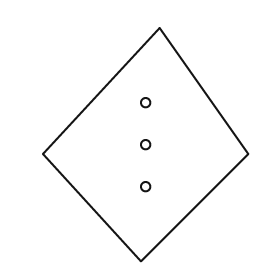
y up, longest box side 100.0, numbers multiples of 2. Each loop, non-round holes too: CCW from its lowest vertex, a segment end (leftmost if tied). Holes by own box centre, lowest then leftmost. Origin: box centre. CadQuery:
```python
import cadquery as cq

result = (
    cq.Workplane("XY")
    .moveTo(-2.0, -50.0)
    .lineTo(44.0, -4.0)
    .lineTo(6.0, 50.0)
    .lineTo(-44.0, -4.0)
    .close()
    .moveTo(0.0, -18.0)
    .circle(2.0)
    .moveTo(0.0, 0.0)
    .circle(2.0)
    .moveTo(0.0, 18.0)
    .circle(2.0)
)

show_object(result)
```